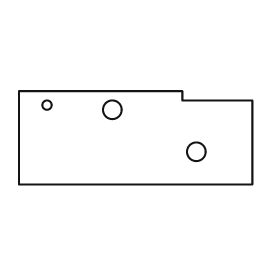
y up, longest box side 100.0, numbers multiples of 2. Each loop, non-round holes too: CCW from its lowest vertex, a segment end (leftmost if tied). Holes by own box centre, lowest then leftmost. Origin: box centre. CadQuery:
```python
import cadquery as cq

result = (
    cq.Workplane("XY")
    .moveTo(-50.0, -20.0)
    .lineTo(50.0, -20.0)
    .lineTo(50.0, 16.0)
    .lineTo(20.0, 16.0)
    .lineTo(20.0, 20.0)
    .lineTo(-50.0, 20.0)
    .close()
    .moveTo(26.0, -6.0)
    .circle(4.0)
    .moveTo(-10.0, 12.0)
    .circle(4.0)
    .moveTo(-38.0, 14.0)
    .circle(2.0)
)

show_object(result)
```